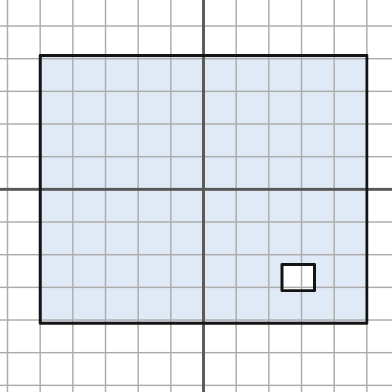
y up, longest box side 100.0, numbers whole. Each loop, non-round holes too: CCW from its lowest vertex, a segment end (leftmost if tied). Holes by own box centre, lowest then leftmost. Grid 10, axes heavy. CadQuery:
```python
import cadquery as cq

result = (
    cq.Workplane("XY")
    .moveTo(-50.0, -41.0)
    .lineTo(50.0, -41.0)
    .lineTo(50.0, 41.0)
    .lineTo(-50.0, 41.0)
    .close()
    .moveTo(24.0, -31.0)
    .lineTo(34.0, -31.0)
    .lineTo(34.0, -23.0)
    .lineTo(24.0, -23.0)
    .close()
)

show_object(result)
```